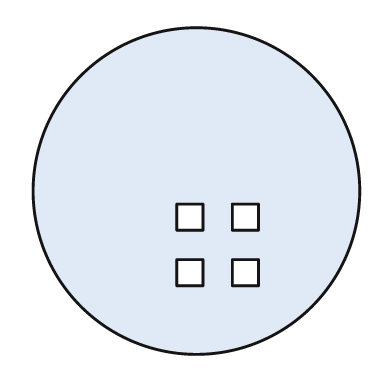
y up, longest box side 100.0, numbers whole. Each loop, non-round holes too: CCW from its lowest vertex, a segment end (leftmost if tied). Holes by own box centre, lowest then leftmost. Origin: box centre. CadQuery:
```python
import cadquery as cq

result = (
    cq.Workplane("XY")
    .moveTo(0.0, 0.0)
    .circle(50.0)
    .moveTo(-6.0, -29.0)
    .lineTo(2.0, -29.0)
    .lineTo(2.0, -21.0)
    .lineTo(-6.0, -21.0)
    .close()
    .moveTo(11.0, -29.0)
    .lineTo(19.0, -29.0)
    .lineTo(19.0, -21.0)
    .lineTo(11.0, -21.0)
    .close()
    .moveTo(-6.0, -12.0)
    .lineTo(2.0, -12.0)
    .lineTo(2.0, -4.0)
    .lineTo(-6.0, -4.0)
    .close()
    .moveTo(11.0, -12.0)
    .lineTo(19.0, -12.0)
    .lineTo(19.0, -4.0)
    .lineTo(11.0, -4.0)
    .close()
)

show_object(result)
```